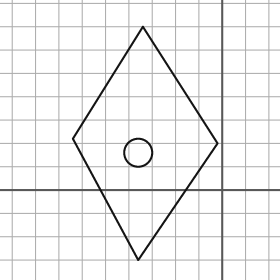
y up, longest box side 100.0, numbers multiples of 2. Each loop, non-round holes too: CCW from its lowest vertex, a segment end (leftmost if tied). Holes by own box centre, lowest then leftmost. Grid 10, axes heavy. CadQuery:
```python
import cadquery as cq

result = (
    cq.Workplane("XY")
    .moveTo(-36.0, -30.0)
    .lineTo(-2.0, 20.0)
    .lineTo(-34.0, 70.0)
    .lineTo(-64.0, 22.0)
    .close()
    .moveTo(-36.0, 16.0)
    .circle(6.0)
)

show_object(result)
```